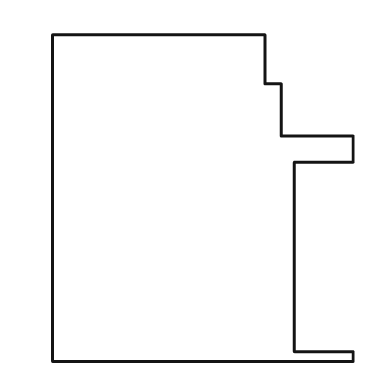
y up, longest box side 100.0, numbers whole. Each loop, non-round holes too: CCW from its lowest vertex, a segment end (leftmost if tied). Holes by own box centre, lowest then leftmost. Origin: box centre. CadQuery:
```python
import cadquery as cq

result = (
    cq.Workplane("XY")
    .moveTo(-46.0, -50.0)
    .lineTo(46.0, -50.0)
    .lineTo(46.0, -47.0)
    .lineTo(28.0, -47.0)
    .lineTo(28.0, 11.0)
    .lineTo(46.0, 11.0)
    .lineTo(46.0, 19.0)
    .lineTo(24.0, 19.0)
    .lineTo(24.0, 35.0)
    .lineTo(19.0, 35.0)
    .lineTo(19.0, 50.0)
    .lineTo(-46.0, 50.0)
    .close()
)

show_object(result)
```